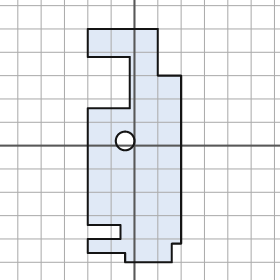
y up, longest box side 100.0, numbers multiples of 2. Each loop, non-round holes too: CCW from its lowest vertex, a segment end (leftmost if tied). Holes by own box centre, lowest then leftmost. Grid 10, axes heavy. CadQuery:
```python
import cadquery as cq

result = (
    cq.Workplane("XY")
    .moveTo(-4.0, -50.0)
    .lineTo(16.0, -50.0)
    .lineTo(16.0, -42.0)
    .lineTo(20.0, -42.0)
    .lineTo(20.0, 30.0)
    .lineTo(10.0, 30.0)
    .lineTo(10.0, 50.0)
    .lineTo(-20.0, 50.0)
    .lineTo(-20.0, 38.0)
    .lineTo(-2.0, 38.0)
    .lineTo(-2.0, 16.0)
    .lineTo(-20.0, 16.0)
    .lineTo(-20.0, -34.0)
    .lineTo(-6.0, -34.0)
    .lineTo(-6.0, -40.0)
    .lineTo(-20.0, -40.0)
    .lineTo(-20.0, -46.0)
    .lineTo(-4.0, -46.0)
    .close()
    .moveTo(-4.0, 2.0)
    .circle(4.0)
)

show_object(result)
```